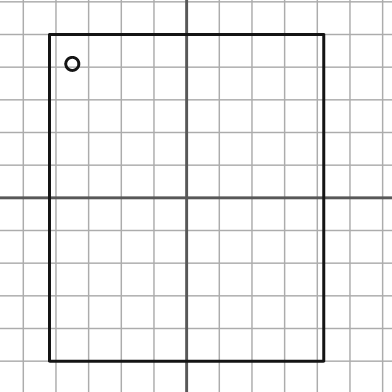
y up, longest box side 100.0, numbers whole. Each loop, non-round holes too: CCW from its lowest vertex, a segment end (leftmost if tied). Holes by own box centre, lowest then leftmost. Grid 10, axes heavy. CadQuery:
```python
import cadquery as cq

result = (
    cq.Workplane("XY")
    .moveTo(-42.0, -50.0)
    .lineTo(42.0, -50.0)
    .lineTo(42.0, 50.0)
    .lineTo(-42.0, 50.0)
    .close()
    .moveTo(-35.0, 41.0)
    .circle(2.0)
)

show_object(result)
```